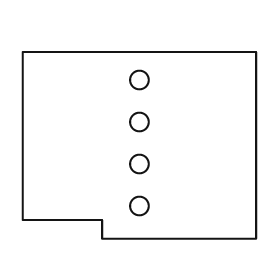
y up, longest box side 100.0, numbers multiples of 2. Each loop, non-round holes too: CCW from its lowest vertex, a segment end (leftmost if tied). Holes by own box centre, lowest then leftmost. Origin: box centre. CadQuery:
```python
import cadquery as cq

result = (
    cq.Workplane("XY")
    .moveTo(-16.0, -40.0)
    .lineTo(50.0, -40.0)
    .lineTo(50.0, 40.0)
    .lineTo(-50.0, 40.0)
    .lineTo(-50.0, -32.0)
    .lineTo(-16.0, -32.0)
    .close()
    .moveTo(0.0, -26.0)
    .circle(4.0)
    .moveTo(0.0, -8.0)
    .circle(4.0)
    .moveTo(0.0, 10.0)
    .circle(4.0)
    .moveTo(0.0, 28.0)
    .circle(4.0)
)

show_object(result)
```